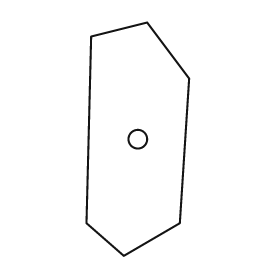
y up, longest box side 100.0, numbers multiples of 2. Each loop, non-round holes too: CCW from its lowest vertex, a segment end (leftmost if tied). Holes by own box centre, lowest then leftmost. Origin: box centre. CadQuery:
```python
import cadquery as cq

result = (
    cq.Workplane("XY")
    .moveTo(-6.0, -50.0)
    .lineTo(18.0, -36.0)
    .lineTo(22.0, 26.0)
    .lineTo(4.0, 50.0)
    .lineTo(-20.0, 44.0)
    .lineTo(-22.0, -36.0)
    .close()
    .moveTo(0.0, 0.0)
    .circle(4.0)
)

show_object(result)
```